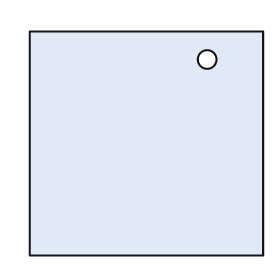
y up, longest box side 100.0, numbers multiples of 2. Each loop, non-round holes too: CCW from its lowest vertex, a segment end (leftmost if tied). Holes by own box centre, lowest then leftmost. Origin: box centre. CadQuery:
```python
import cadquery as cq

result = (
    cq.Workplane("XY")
    .moveTo(-50.0, -48.0)
    .lineTo(50.0, -48.0)
    .lineTo(50.0, 48.0)
    .lineTo(-50.0, 48.0)
    .close()
    .moveTo(26.0, 36.0)
    .circle(4.0)
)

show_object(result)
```